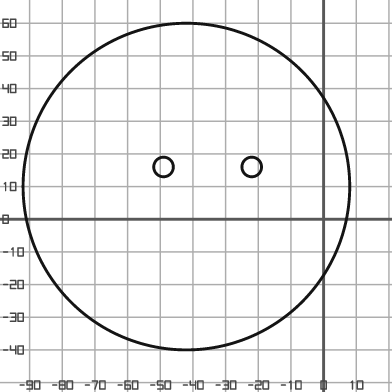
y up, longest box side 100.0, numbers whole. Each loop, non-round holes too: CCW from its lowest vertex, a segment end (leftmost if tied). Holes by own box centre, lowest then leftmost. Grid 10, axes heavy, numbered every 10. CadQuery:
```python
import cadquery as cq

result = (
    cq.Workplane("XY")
    .moveTo(-42.0, 10.0)
    .circle(50.0)
    .moveTo(-49.0, 16.0)
    .circle(3.0)
    .moveTo(-22.0, 16.0)
    .circle(3.0)
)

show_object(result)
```